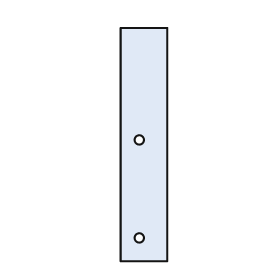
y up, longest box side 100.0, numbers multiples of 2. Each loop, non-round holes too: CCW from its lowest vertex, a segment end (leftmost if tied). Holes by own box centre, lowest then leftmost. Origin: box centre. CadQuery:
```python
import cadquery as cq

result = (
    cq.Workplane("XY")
    .moveTo(-10.0, -50.0)
    .lineTo(10.0, -50.0)
    .lineTo(10.0, 50.0)
    .lineTo(-10.0, 50.0)
    .close()
    .moveTo(-2.0, -40.0)
    .circle(2.0)
    .moveTo(-2.0, 2.0)
    .circle(2.0)
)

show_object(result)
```